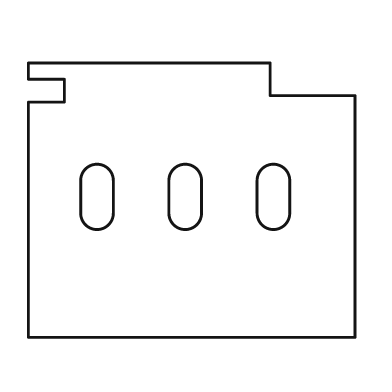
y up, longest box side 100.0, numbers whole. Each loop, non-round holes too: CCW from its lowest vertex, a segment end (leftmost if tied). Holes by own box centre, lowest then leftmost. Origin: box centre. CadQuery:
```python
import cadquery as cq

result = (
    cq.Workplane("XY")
    .moveTo(-50.0, -42.0)
    .lineTo(50.0, -42.0)
    .lineTo(50.0, 32.0)
    .lineTo(24.0, 32.0)
    .lineTo(24.0, 42.0)
    .lineTo(-50.0, 42.0)
    .lineTo(-50.0, 37.0)
    .lineTo(-39.0, 37.0)
    .lineTo(-39.0, 30.0)
    .lineTo(-50.0, 30.0)
    .close()
    .moveTo(-34.0, -4.0)
    .threePointArc((-29.0, -9.0), (-24.0, -4.0))
    .lineTo(-24.0, 6.0)
    .threePointArc((-29.0, 11.0), (-34.0, 6.0))
    .close()
    .moveTo(-7.0, -4.0)
    .threePointArc((-2.0, -9.0), (3.0, -4.0))
    .lineTo(3.0, 6.0)
    .threePointArc((-2.0, 11.0), (-7.0, 6.0))
    .close()
    .moveTo(20.0, -4.0)
    .threePointArc((25.0, -9.0), (30.0, -4.0))
    .lineTo(30.0, 6.0)
    .threePointArc((25.0, 11.0), (20.0, 6.0))
    .close()
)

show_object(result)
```